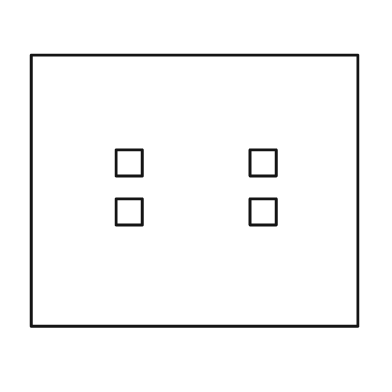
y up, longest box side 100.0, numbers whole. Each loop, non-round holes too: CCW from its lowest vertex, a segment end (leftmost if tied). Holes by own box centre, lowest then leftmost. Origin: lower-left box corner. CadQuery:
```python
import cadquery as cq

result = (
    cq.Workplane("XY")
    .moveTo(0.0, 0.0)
    .lineTo(100.0, 0.0)
    .lineTo(100.0, 83.0)
    .lineTo(0.0, 83.0)
    .close()
    .moveTo(26.0, 31.0)
    .lineTo(34.0, 31.0)
    .lineTo(34.0, 39.0)
    .lineTo(26.0, 39.0)
    .close()
    .moveTo(67.0, 31.0)
    .lineTo(75.0, 31.0)
    .lineTo(75.0, 39.0)
    .lineTo(67.0, 39.0)
    .close()
    .moveTo(26.0, 46.0)
    .lineTo(34.0, 46.0)
    .lineTo(34.0, 54.0)
    .lineTo(26.0, 54.0)
    .close()
    .moveTo(67.0, 46.0)
    .lineTo(75.0, 46.0)
    .lineTo(75.0, 54.0)
    .lineTo(67.0, 54.0)
    .close()
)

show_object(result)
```